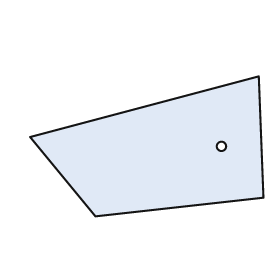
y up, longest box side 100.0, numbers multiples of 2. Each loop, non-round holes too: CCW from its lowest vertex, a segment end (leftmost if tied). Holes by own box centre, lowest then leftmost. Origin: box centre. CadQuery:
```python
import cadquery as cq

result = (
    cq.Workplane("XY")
    .moveTo(-22.0, -30.0)
    .lineTo(50.0, -22.0)
    .lineTo(48.0, 30.0)
    .lineTo(-50.0, 4.0)
    .close()
    .moveTo(32.0, 0.0)
    .circle(2.0)
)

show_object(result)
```